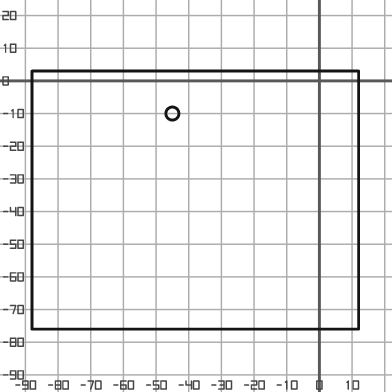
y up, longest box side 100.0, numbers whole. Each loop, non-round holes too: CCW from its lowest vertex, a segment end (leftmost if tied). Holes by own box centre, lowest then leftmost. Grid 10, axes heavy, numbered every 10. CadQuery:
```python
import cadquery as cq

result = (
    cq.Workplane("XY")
    .moveTo(-88.0, -76.0)
    .lineTo(12.0, -76.0)
    .lineTo(12.0, 3.0)
    .lineTo(-88.0, 3.0)
    .close()
    .moveTo(-45.0, -10.0)
    .circle(2.0)
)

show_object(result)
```